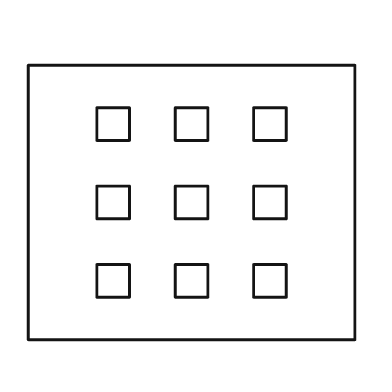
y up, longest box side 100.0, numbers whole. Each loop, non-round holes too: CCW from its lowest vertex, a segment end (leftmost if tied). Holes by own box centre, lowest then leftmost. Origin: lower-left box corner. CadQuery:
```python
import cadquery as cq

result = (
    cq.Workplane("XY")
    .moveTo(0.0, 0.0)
    .lineTo(100.0, 0.0)
    .lineTo(100.0, 84.0)
    .lineTo(0.0, 84.0)
    .close()
    .moveTo(21.0, 13.0)
    .lineTo(31.0, 13.0)
    .lineTo(31.0, 23.0)
    .lineTo(21.0, 23.0)
    .close()
    .moveTo(45.0, 13.0)
    .lineTo(55.0, 13.0)
    .lineTo(55.0, 23.0)
    .lineTo(45.0, 23.0)
    .close()
    .moveTo(69.0, 13.0)
    .lineTo(79.0, 13.0)
    .lineTo(79.0, 23.0)
    .lineTo(69.0, 23.0)
    .close()
    .moveTo(21.0, 37.0)
    .lineTo(31.0, 37.0)
    .lineTo(31.0, 47.0)
    .lineTo(21.0, 47.0)
    .close()
    .moveTo(45.0, 37.0)
    .lineTo(55.0, 37.0)
    .lineTo(55.0, 47.0)
    .lineTo(45.0, 47.0)
    .close()
    .moveTo(69.0, 37.0)
    .lineTo(79.0, 37.0)
    .lineTo(79.0, 47.0)
    .lineTo(69.0, 47.0)
    .close()
    .moveTo(21.0, 61.0)
    .lineTo(31.0, 61.0)
    .lineTo(31.0, 71.0)
    .lineTo(21.0, 71.0)
    .close()
    .moveTo(45.0, 61.0)
    .lineTo(55.0, 61.0)
    .lineTo(55.0, 71.0)
    .lineTo(45.0, 71.0)
    .close()
    .moveTo(69.0, 61.0)
    .lineTo(79.0, 61.0)
    .lineTo(79.0, 71.0)
    .lineTo(69.0, 71.0)
    .close()
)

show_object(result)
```